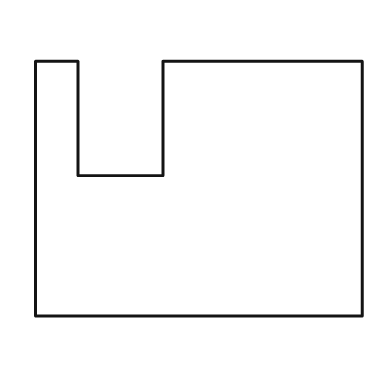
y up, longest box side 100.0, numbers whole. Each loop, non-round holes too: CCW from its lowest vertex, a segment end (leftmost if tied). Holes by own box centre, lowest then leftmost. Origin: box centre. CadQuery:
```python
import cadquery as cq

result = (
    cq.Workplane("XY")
    .moveTo(-50.0, -39.0)
    .lineTo(50.0, -39.0)
    .lineTo(50.0, 39.0)
    .lineTo(-11.0, 39.0)
    .lineTo(-11.0, 4.0)
    .lineTo(-37.0, 4.0)
    .lineTo(-37.0, 39.0)
    .lineTo(-50.0, 39.0)
    .close()
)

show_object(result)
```